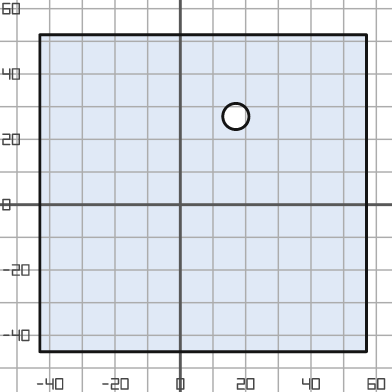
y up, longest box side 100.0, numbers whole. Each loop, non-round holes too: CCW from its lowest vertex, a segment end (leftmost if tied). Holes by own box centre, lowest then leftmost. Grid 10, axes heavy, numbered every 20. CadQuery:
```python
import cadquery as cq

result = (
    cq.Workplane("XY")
    .moveTo(-43.0, -45.0)
    .lineTo(57.0, -45.0)
    .lineTo(57.0, 52.0)
    .lineTo(-43.0, 52.0)
    .close()
    .moveTo(17.0, 27.0)
    .circle(4.0)
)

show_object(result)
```